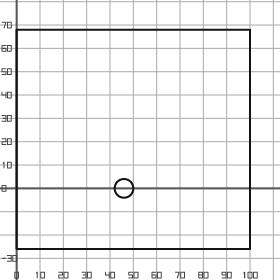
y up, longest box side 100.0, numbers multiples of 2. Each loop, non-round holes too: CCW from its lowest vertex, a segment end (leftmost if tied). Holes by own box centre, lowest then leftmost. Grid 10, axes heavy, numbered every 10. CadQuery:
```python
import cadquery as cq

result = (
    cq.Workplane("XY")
    .moveTo(0.0, -26.0)
    .lineTo(100.0, -26.0)
    .lineTo(100.0, 68.0)
    .lineTo(0.0, 68.0)
    .close()
    .moveTo(46.0, 0.0)
    .circle(4.0)
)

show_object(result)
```